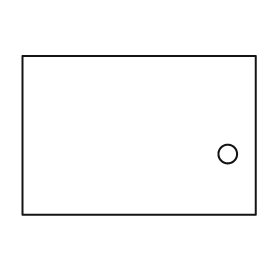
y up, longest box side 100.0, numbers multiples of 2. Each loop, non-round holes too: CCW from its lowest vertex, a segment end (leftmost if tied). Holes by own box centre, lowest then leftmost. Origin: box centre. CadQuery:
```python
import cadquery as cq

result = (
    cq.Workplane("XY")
    .moveTo(-50.0, -34.0)
    .lineTo(50.0, -34.0)
    .lineTo(50.0, 34.0)
    .lineTo(-50.0, 34.0)
    .close()
    .moveTo(38.0, -8.0)
    .circle(4.0)
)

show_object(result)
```